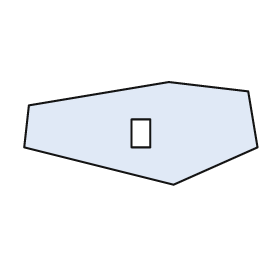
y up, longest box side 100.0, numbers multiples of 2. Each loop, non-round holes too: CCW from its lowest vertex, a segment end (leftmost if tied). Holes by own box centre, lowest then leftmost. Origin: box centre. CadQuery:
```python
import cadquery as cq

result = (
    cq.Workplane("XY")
    .moveTo(14.0, -22.0)
    .lineTo(50.0, -6.0)
    .lineTo(46.0, 18.0)
    .lineTo(12.0, 22.0)
    .lineTo(-48.0, 12.0)
    .lineTo(-50.0, -6.0)
    .close()
    .moveTo(-4.0, -6.0)
    .lineTo(4.0, -6.0)
    .lineTo(4.0, 6.0)
    .lineTo(-4.0, 6.0)
    .close()
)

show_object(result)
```